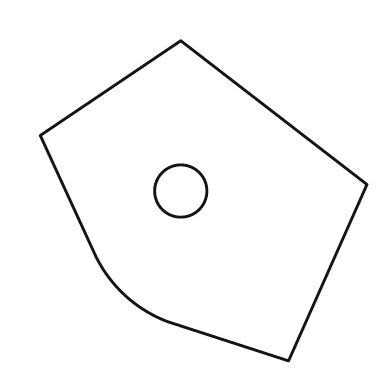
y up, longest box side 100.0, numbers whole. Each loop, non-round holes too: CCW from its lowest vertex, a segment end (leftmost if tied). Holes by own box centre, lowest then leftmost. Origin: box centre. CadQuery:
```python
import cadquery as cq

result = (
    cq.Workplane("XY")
    .moveTo(26.0, -49.0)
    .lineTo(50.0, 5.0)
    .lineTo(-7.0, 49.0)
    .lineTo(-50.0, 20.0)
    .lineTo(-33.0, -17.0)
    .threePointArc((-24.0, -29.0), (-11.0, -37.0))
    .close()
    .moveTo(-7.0, 3.0)
    .circle(8.0)
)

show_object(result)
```